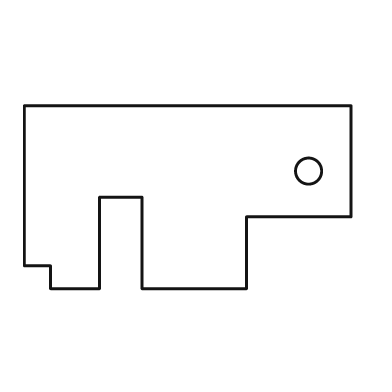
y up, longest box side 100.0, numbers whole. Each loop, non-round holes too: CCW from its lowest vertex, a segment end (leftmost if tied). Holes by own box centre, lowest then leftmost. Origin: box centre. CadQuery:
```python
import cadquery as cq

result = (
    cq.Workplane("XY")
    .moveTo(-42.0, -28.0)
    .lineTo(-27.0, -28.0)
    .lineTo(-27.0, 0.0)
    .lineTo(-14.0, 0.0)
    .lineTo(-14.0, -28.0)
    .lineTo(18.0, -28.0)
    .lineTo(18.0, -6.0)
    .lineTo(50.0, -6.0)
    .lineTo(50.0, 28.0)
    .lineTo(-50.0, 28.0)
    .lineTo(-50.0, -21.0)
    .lineTo(-42.0, -21.0)
    .close()
    .moveTo(37.0, 8.0)
    .circle(4.0)
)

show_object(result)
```